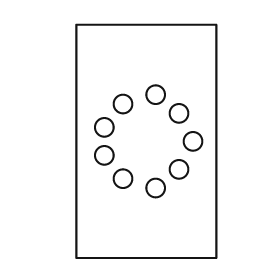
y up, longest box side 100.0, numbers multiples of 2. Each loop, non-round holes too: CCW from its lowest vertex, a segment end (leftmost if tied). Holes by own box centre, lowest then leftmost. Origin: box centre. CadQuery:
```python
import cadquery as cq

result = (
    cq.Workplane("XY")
    .moveTo(-30.0, -50.0)
    .lineTo(30.0, -50.0)
    .lineTo(30.0, 50.0)
    .lineTo(-30.0, 50.0)
    .close()
    .moveTo(4.0, -20.0)
    .circle(4.0)
    .moveTo(-10.0, -16.0)
    .circle(4.0)
    .moveTo(14.0, -12.0)
    .circle(4.0)
    .moveTo(-18.0, -6.0)
    .circle(4.0)
    .moveTo(20.0, 0.0)
    .circle(4.0)
    .moveTo(-18.0, 6.0)
    .circle(4.0)
    .moveTo(14.0, 12.0)
    .circle(4.0)
    .moveTo(-10.0, 16.0)
    .circle(4.0)
    .moveTo(4.0, 20.0)
    .circle(4.0)
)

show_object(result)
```